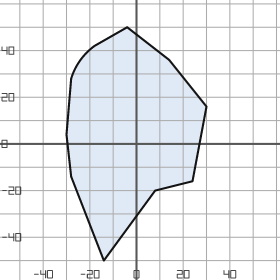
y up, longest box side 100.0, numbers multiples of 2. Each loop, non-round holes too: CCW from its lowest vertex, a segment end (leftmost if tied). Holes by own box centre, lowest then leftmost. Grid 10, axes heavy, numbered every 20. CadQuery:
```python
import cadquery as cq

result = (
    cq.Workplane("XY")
    .moveTo(-14.0, -50.0)
    .lineTo(8.0, -20.0)
    .lineTo(24.0, -16.0)
    .lineTo(30.0, 16.0)
    .lineTo(14.0, 36.0)
    .lineTo(-4.0, 50.0)
    .lineTo(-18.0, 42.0)
    .threePointArc((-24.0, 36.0), (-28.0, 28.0))
    .lineTo(-30.0, 4.0)
    .lineTo(-28.0, -14.0)
    .close()
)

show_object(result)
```